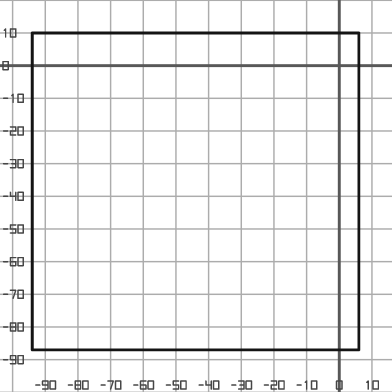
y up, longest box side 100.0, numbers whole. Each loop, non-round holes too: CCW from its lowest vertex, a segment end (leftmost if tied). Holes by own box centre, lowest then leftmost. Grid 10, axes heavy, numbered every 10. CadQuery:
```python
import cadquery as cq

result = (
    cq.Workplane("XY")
    .moveTo(-94.0, -87.0)
    .lineTo(6.0, -87.0)
    .lineTo(6.0, 10.0)
    .lineTo(-94.0, 10.0)
    .close()
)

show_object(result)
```